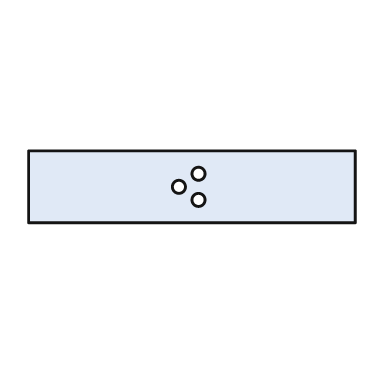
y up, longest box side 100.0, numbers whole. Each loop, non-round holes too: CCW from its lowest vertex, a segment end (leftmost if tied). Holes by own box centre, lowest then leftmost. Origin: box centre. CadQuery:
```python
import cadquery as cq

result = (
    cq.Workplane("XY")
    .moveTo(-50.0, -11.0)
    .lineTo(50.0, -11.0)
    .lineTo(50.0, 11.0)
    .lineTo(-50.0, 11.0)
    .close()
    .moveTo(2.0, -4.0)
    .circle(2.0)
    .moveTo(-4.0, 0.0)
    .circle(2.0)
    .moveTo(2.0, 4.0)
    .circle(2.0)
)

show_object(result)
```